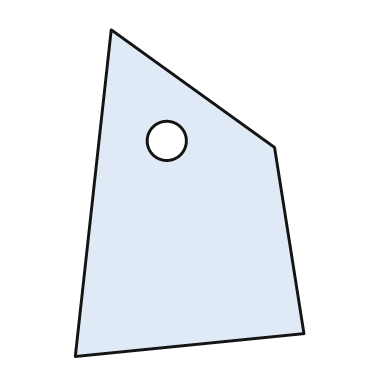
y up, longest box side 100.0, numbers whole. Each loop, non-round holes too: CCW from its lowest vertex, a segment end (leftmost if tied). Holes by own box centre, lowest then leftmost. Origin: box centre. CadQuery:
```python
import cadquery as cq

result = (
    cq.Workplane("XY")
    .moveTo(-35.0, -50.0)
    .lineTo(35.0, -43.0)
    .lineTo(26.0, 14.0)
    .lineTo(-24.0, 50.0)
    .close()
    .moveTo(-7.0, 16.0)
    .circle(6.0)
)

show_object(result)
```